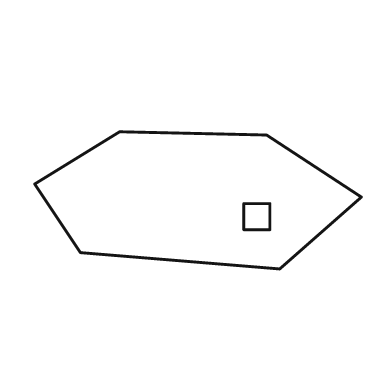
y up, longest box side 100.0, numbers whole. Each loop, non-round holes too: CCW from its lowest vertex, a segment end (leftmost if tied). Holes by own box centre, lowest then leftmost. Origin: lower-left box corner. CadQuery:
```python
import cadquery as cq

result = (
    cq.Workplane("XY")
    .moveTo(75.0, 0.0)
    .lineTo(100.0, 22.0)
    .lineTo(71.0, 41.0)
    .lineTo(26.0, 42.0)
    .lineTo(0.0, 26.0)
    .lineTo(14.0, 5.0)
    .close()
    .moveTo(64.0, 12.0)
    .lineTo(72.0, 12.0)
    .lineTo(72.0, 20.0)
    .lineTo(64.0, 20.0)
    .close()
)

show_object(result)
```